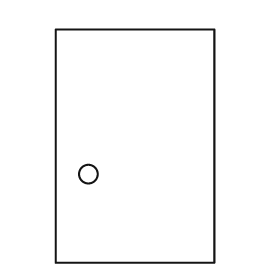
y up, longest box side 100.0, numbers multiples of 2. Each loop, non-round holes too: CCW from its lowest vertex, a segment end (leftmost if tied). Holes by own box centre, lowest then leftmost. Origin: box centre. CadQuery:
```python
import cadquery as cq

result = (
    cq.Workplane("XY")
    .moveTo(-34.0, -50.0)
    .lineTo(34.0, -50.0)
    .lineTo(34.0, 50.0)
    .lineTo(-34.0, 50.0)
    .close()
    .moveTo(-20.0, -12.0)
    .circle(4.0)
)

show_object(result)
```